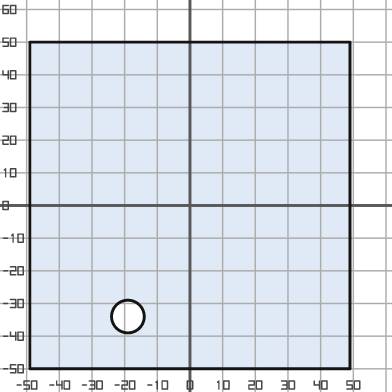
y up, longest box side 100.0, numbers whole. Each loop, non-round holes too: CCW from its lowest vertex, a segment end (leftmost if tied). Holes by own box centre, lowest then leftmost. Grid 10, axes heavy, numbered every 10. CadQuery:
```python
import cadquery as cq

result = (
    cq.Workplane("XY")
    .moveTo(-49.0, -50.0)
    .lineTo(49.0, -50.0)
    .lineTo(49.0, 50.0)
    .lineTo(-49.0, 50.0)
    .close()
    .moveTo(-19.0, -34.0)
    .circle(5.0)
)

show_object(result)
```